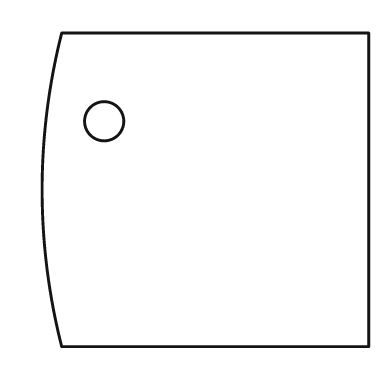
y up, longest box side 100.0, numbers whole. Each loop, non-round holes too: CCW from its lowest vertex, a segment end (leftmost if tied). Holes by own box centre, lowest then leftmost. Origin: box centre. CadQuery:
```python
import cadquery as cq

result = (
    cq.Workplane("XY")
    .moveTo(-44.0, -48.0)
    .lineTo(50.0, -48.0)
    .lineTo(50.0, 48.0)
    .lineTo(-44.0, 48.0)
    .threePointArc((-50.0, 0.0), (-44.0, -48.0))
    .close()
    .moveTo(-31.0, 21.0)
    .circle(6.0)
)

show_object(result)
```